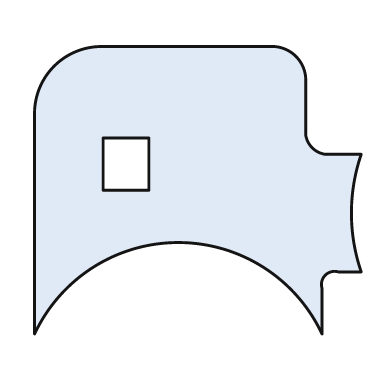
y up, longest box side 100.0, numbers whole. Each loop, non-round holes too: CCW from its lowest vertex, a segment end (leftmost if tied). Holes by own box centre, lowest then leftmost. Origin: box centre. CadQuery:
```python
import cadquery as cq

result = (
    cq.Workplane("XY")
    .moveTo(-50.0, -44.0)
    .threePointArc((-6.0, -16.0), (38.0, -44.0))
    .lineTo(38.0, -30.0)
    .threePointArc((39.0, -26.0), (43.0, -25.0))
    .lineTo(50.0, -25.0)
    .threePointArc((47.0, -7.0), (50.0, 11.0))
    .lineTo(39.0, 11.0)
    .threePointArc((35.0, 13.0), (33.0, 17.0))
    .lineTo(33.0, 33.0)
    .threePointArc((30.0, 41.0), (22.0, 44.0))
    .lineTo(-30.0, 44.0)
    .threePointArc((-44.0, 38.0), (-50.0, 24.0))
    .close()
    .moveTo(-29.0, 0.0)
    .lineTo(-15.0, 0.0)
    .lineTo(-15.0, 16.0)
    .lineTo(-29.0, 16.0)
    .close()
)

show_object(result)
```